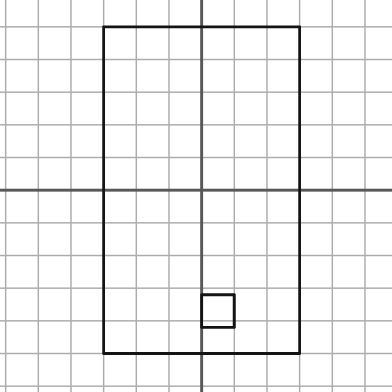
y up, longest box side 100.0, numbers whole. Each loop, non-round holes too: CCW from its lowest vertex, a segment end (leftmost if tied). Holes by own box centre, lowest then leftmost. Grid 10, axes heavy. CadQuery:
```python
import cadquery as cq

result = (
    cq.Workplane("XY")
    .moveTo(-30.0, -50.0)
    .lineTo(30.0, -50.0)
    .lineTo(30.0, 50.0)
    .lineTo(-30.0, 50.0)
    .close()
    .moveTo(0.0, -42.0)
    .lineTo(10.0, -42.0)
    .lineTo(10.0, -32.0)
    .lineTo(0.0, -32.0)
    .close()
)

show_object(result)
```